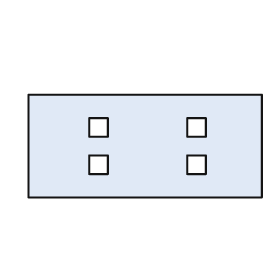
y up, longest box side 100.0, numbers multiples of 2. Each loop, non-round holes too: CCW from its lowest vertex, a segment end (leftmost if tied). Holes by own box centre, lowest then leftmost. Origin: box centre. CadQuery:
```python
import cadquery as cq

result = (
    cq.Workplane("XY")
    .moveTo(-50.0, -22.0)
    .lineTo(50.0, -22.0)
    .lineTo(50.0, 22.0)
    .lineTo(-50.0, 22.0)
    .close()
    .moveTo(-24.0, -12.0)
    .lineTo(-16.0, -12.0)
    .lineTo(-16.0, -4.0)
    .lineTo(-24.0, -4.0)
    .close()
    .moveTo(18.0, -12.0)
    .lineTo(26.0, -12.0)
    .lineTo(26.0, -4.0)
    .lineTo(18.0, -4.0)
    .close()
    .moveTo(-24.0, 4.0)
    .lineTo(-16.0, 4.0)
    .lineTo(-16.0, 12.0)
    .lineTo(-24.0, 12.0)
    .close()
    .moveTo(18.0, 4.0)
    .lineTo(26.0, 4.0)
    .lineTo(26.0, 12.0)
    .lineTo(18.0, 12.0)
    .close()
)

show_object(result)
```